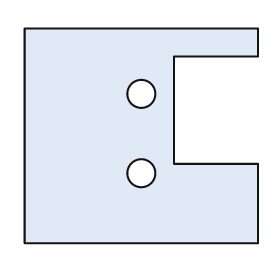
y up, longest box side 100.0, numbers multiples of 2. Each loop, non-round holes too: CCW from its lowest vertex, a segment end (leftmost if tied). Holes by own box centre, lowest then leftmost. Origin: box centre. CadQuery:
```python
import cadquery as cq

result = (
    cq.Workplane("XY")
    .moveTo(-50.0, -46.0)
    .lineTo(50.0, -46.0)
    .lineTo(50.0, -12.0)
    .lineTo(14.0, -12.0)
    .lineTo(14.0, 34.0)
    .lineTo(50.0, 34.0)
    .lineTo(50.0, 46.0)
    .lineTo(-50.0, 46.0)
    .close()
    .moveTo(0.0, -16.0)
    .circle(6.0)
    .moveTo(0.0, 18.0)
    .circle(6.0)
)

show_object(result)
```